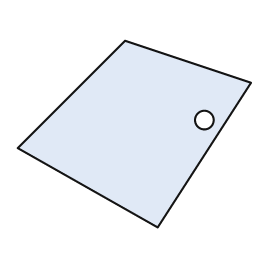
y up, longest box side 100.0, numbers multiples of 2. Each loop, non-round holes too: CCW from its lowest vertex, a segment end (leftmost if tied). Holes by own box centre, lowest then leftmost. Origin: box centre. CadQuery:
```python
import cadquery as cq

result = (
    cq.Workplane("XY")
    .moveTo(10.0, -40.0)
    .lineTo(50.0, 22.0)
    .lineTo(-4.0, 40.0)
    .lineTo(-50.0, -6.0)
    .close()
    .moveTo(30.0, 6.0)
    .circle(4.0)
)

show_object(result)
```